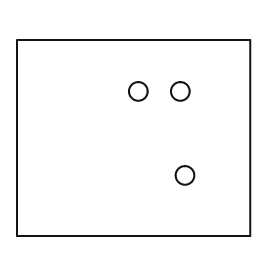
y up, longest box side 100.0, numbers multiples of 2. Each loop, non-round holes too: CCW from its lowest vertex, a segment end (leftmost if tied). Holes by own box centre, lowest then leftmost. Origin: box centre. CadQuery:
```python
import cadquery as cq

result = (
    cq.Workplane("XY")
    .moveTo(-50.0, -42.0)
    .lineTo(50.0, -42.0)
    .lineTo(50.0, 42.0)
    .lineTo(-50.0, 42.0)
    .close()
    .moveTo(22.0, -16.0)
    .circle(4.0)
    .moveTo(2.0, 20.0)
    .circle(4.0)
    .moveTo(20.0, 20.0)
    .circle(4.0)
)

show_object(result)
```